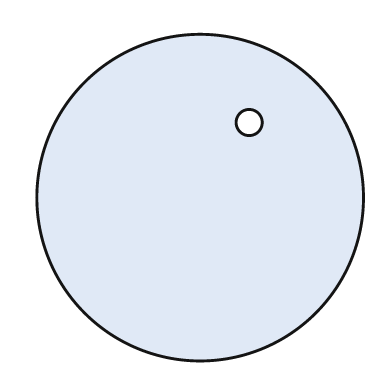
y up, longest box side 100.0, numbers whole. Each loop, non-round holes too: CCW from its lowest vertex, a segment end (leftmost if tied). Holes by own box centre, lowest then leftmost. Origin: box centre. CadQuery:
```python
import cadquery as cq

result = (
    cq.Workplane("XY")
    .moveTo(0.0, 0.0)
    .circle(50.0)
    .moveTo(15.0, 23.0)
    .circle(4.0)
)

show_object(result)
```